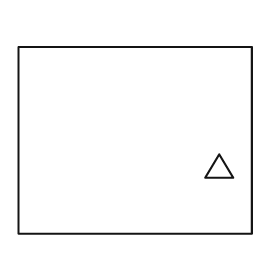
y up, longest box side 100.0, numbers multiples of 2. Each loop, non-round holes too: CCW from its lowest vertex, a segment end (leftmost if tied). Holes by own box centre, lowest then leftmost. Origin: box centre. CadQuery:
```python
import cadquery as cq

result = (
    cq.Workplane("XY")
    .moveTo(-50.0, -40.0)
    .lineTo(50.0, -40.0)
    .lineTo(50.0, 40.0)
    .lineTo(-50.0, 40.0)
    .close()
    .moveTo(30.0, -16.0)
    .lineTo(42.0, -16.0)
    .lineTo(36.0, -6.0)
    .close()
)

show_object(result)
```